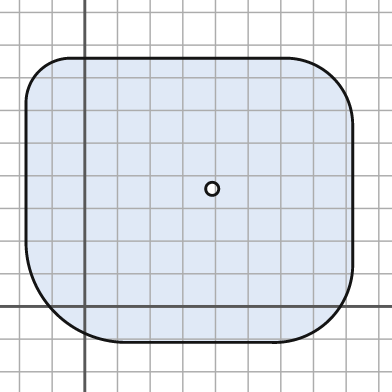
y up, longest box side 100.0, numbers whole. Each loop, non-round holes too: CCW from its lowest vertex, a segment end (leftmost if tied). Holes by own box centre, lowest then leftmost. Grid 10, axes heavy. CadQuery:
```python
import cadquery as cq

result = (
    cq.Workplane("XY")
    .moveTo(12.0, -11.0)
    .lineTo(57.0, -11.0)
    .threePointArc((75.0, -4.0), (82.0, 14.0))
    .lineTo(82.0, 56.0)
    .threePointArc((76.0, 70.0), (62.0, 76.0))
    .lineTo(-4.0, 76.0)
    .threePointArc((-14.0, 72.0), (-18.0, 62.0))
    .lineTo(-18.0, 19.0)
    .threePointArc((-9.0, -2.0), (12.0, -11.0))
    .close()
    .moveTo(39.0, 36.0)
    .circle(2.0)
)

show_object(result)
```